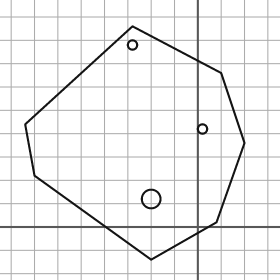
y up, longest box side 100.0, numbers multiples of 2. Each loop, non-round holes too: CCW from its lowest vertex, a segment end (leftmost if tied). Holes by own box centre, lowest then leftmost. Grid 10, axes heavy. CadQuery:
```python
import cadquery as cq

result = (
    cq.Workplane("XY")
    .moveTo(-20.0, -14.0)
    .lineTo(8.0, 2.0)
    .lineTo(20.0, 36.0)
    .lineTo(10.0, 66.0)
    .lineTo(-28.0, 86.0)
    .lineTo(-74.0, 44.0)
    .lineTo(-70.0, 22.0)
    .close()
    .moveTo(-20.0, 12.0)
    .circle(4.0)
    .moveTo(2.0, 42.0)
    .circle(2.0)
    .moveTo(-28.0, 78.0)
    .circle(2.0)
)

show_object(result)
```